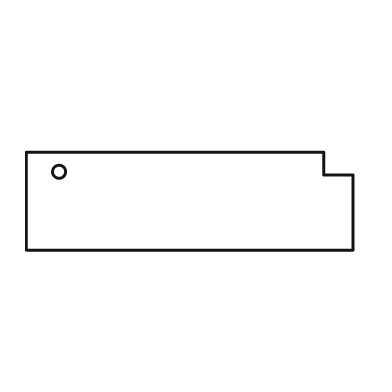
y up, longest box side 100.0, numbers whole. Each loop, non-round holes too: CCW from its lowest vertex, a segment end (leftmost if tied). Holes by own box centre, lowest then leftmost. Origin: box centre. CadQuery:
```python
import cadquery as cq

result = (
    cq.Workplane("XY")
    .moveTo(-50.0, -15.0)
    .lineTo(50.0, -15.0)
    .lineTo(50.0, 8.0)
    .lineTo(41.0, 8.0)
    .lineTo(41.0, 15.0)
    .lineTo(-50.0, 15.0)
    .close()
    .moveTo(-40.0, 9.0)
    .circle(2.0)
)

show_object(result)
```